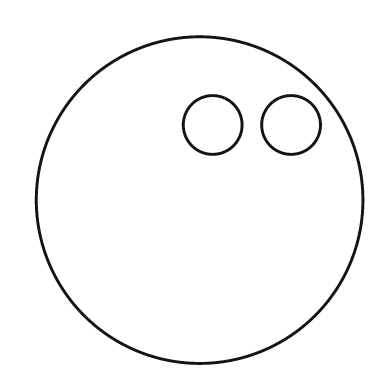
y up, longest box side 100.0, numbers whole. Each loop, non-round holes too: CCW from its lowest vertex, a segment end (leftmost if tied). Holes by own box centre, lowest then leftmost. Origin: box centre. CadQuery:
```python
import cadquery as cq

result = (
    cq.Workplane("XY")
    .moveTo(0.0, 0.0)
    .circle(50.0)
    .moveTo(4.0, 23.0)
    .circle(9.0)
    .moveTo(28.0, 23.0)
    .circle(9.0)
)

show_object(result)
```